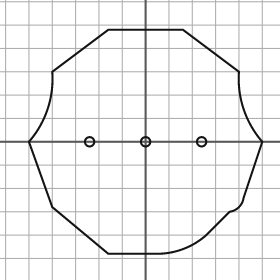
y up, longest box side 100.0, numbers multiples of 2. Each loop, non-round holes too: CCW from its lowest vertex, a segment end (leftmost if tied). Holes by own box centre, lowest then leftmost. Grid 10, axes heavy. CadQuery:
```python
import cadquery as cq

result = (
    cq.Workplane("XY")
    .moveTo(-16.0, -48.0)
    .lineTo(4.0, -48.0)
    .threePointArc((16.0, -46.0), (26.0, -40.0))
    .lineTo(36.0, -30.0)
    .threePointArc((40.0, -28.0), (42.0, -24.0))
    .lineTo(50.0, 0.0)
    .threePointArc((42.0, 14.0), (40.0, 30.0))
    .lineTo(16.0, 48.0)
    .lineTo(-16.0, 48.0)
    .lineTo(-40.0, 30.0)
    .threePointArc((-42.0, 14.0), (-50.0, 0.0))
    .lineTo(-40.0, -28.0)
    .close()
    .moveTo(-24.0, 0.0)
    .circle(2.0)
    .moveTo(0.0, 0.0)
    .circle(2.0)
    .moveTo(24.0, 0.0)
    .circle(2.0)
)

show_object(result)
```